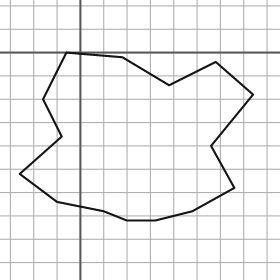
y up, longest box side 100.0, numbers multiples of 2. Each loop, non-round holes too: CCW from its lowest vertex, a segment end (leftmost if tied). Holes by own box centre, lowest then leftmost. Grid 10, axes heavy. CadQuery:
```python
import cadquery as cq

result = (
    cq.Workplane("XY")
    .moveTo(20.0, -72.0)
    .lineTo(32.0, -72.0)
    .lineTo(48.0, -68.0)
    .lineTo(66.0, -58.0)
    .lineTo(56.0, -40.0)
    .lineTo(74.0, -18.0)
    .lineTo(58.0, -4.0)
    .lineTo(38.0, -14.0)
    .lineTo(18.0, -2.0)
    .lineTo(-6.0, 0.0)
    .lineTo(-16.0, -20.0)
    .lineTo(-8.0, -36.0)
    .lineTo(-26.0, -52.0)
    .lineTo(-10.0, -64.0)
    .lineTo(10.0, -68.0)
    .close()
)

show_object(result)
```